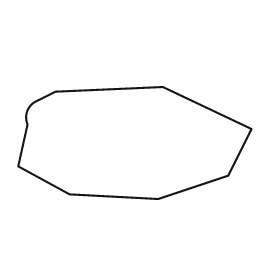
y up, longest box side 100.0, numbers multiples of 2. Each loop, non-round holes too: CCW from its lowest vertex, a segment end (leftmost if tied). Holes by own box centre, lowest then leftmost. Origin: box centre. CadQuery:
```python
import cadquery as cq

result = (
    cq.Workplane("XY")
    .moveTo(10.0, -24.0)
    .lineTo(40.0, -14.0)
    .lineTo(50.0, 6.0)
    .lineTo(12.0, 24.0)
    .lineTo(-34.0, 22.0)
    .lineTo(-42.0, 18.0)
    .threePointArc((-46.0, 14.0), (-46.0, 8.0))
    .lineTo(-50.0, -10.0)
    .lineTo(-28.0, -22.0)
    .close()
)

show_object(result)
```